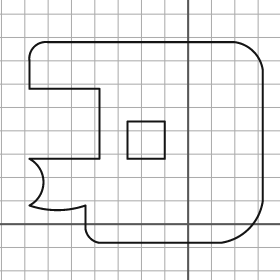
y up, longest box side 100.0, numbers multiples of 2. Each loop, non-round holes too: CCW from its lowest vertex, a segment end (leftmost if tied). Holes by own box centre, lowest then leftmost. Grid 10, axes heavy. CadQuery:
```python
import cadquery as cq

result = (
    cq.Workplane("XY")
    .moveTo(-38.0, -8.0)
    .lineTo(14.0, -8.0)
    .threePointArc((26.0, -2.0), (32.0, 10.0))
    .lineTo(32.0, 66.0)
    .threePointArc((28.0, 74.0), (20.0, 78.0))
    .lineTo(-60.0, 78.0)
    .threePointArc((-66.0, 76.0), (-68.0, 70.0))
    .lineTo(-68.0, 58.0)
    .lineTo(-38.0, 58.0)
    .lineTo(-38.0, 28.0)
    .lineTo(-68.0, 28.0)
    .threePointArc((-62.0, 18.0), (-68.0, 8.0))
    .threePointArc((-56.0, 6.0), (-44.0, 8.0))
    .lineTo(-44.0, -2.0)
    .threePointArc((-42.0, -6.0), (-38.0, -8.0))
    .close()
    .moveTo(-26.0, 28.0)
    .lineTo(-10.0, 28.0)
    .lineTo(-10.0, 44.0)
    .lineTo(-26.0, 44.0)
    .close()
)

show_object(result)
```